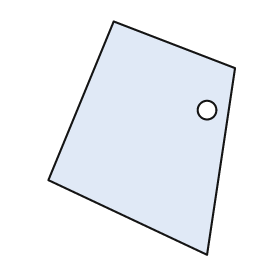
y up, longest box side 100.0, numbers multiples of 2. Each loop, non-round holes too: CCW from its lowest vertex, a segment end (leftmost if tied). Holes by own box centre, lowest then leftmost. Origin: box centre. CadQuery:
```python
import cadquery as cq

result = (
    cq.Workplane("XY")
    .moveTo(28.0, -50.0)
    .lineTo(40.0, 30.0)
    .lineTo(-12.0, 50.0)
    .lineTo(-40.0, -18.0)
    .close()
    .moveTo(28.0, 12.0)
    .circle(4.0)
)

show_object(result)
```